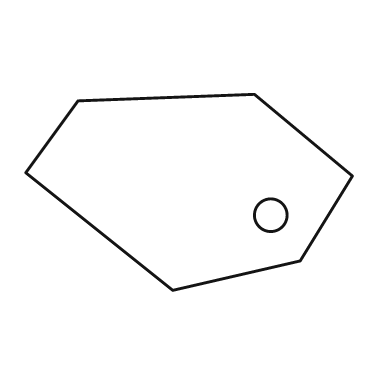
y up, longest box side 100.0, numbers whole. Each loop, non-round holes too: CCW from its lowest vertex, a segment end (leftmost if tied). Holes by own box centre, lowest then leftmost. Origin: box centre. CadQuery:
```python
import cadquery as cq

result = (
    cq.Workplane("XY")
    .moveTo(-5.0, -30.0)
    .lineTo(34.0, -21.0)
    .lineTo(50.0, 5.0)
    .lineTo(20.0, 30.0)
    .lineTo(-34.0, 28.0)
    .lineTo(-50.0, 6.0)
    .close()
    .moveTo(25.0, -7.0)
    .circle(5.0)
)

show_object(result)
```